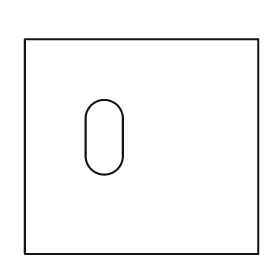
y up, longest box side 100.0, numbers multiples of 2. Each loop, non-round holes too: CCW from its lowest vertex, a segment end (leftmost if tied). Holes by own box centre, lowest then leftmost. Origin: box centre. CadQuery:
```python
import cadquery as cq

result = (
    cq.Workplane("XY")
    .moveTo(-50.0, -46.0)
    .lineTo(50.0, -46.0)
    .lineTo(50.0, 46.0)
    .lineTo(-50.0, 46.0)
    .close()
    .moveTo(-24.0, -4.0)
    .threePointArc((-16.0, -12.0), (-8.0, -4.0))
    .lineTo(-8.0, 12.0)
    .threePointArc((-16.0, 20.0), (-24.0, 12.0))
    .close()
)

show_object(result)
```